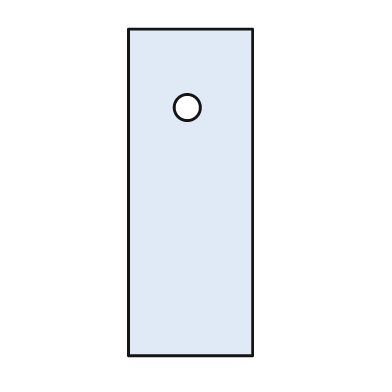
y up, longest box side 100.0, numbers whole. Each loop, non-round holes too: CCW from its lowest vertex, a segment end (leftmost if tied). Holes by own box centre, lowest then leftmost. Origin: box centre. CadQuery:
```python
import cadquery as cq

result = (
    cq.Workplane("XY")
    .moveTo(-19.0, -50.0)
    .lineTo(19.0, -50.0)
    .lineTo(19.0, 50.0)
    .lineTo(-19.0, 50.0)
    .close()
    .moveTo(-1.0, 26.0)
    .circle(4.0)
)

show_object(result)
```